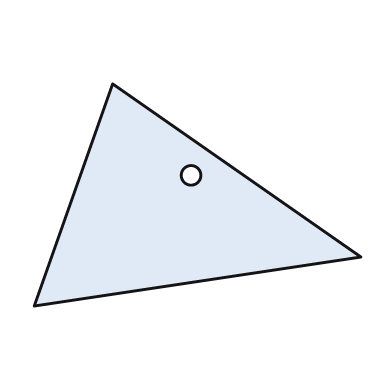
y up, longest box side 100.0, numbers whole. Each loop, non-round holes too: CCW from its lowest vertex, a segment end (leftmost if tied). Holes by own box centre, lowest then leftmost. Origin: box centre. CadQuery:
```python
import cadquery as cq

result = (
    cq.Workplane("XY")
    .moveTo(-50.0, -34.0)
    .lineTo(50.0, -19.0)
    .lineTo(-26.0, 34.0)
    .close()
    .moveTo(-2.0, 6.0)
    .circle(3.0)
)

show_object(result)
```